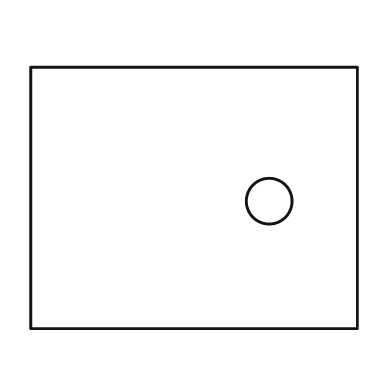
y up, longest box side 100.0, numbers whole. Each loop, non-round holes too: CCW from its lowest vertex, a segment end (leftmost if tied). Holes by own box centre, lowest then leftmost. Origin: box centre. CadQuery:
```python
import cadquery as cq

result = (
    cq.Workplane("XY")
    .moveTo(-50.0, -40.0)
    .lineTo(50.0, -40.0)
    .lineTo(50.0, 40.0)
    .lineTo(-50.0, 40.0)
    .close()
    .moveTo(23.0, -1.0)
    .circle(7.0)
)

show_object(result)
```